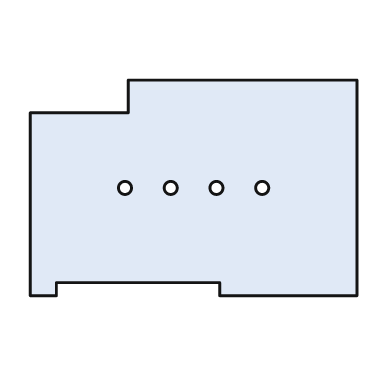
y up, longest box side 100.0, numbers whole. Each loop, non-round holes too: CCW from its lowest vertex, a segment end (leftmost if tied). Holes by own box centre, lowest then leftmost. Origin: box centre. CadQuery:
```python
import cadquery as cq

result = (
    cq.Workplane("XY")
    .moveTo(-50.0, -33.0)
    .lineTo(-42.0, -33.0)
    .lineTo(-42.0, -29.0)
    .lineTo(8.0, -29.0)
    .lineTo(8.0, -33.0)
    .lineTo(50.0, -33.0)
    .lineTo(50.0, 33.0)
    .lineTo(-20.0, 33.0)
    .lineTo(-20.0, 23.0)
    .lineTo(-50.0, 23.0)
    .close()
    .moveTo(-21.0, 0.0)
    .circle(2.0)
    .moveTo(-7.0, 0.0)
    .circle(2.0)
    .moveTo(7.0, 0.0)
    .circle(2.0)
    .moveTo(21.0, 0.0)
    .circle(2.0)
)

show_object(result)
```